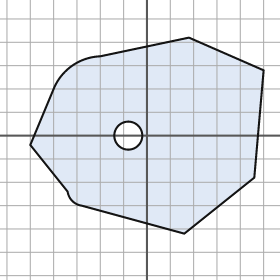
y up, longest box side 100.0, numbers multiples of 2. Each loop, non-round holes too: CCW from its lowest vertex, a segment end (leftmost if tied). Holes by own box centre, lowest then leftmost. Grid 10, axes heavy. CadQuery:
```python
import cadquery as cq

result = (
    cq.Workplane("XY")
    .moveTo(16.0, -42.0)
    .lineTo(46.0, -18.0)
    .lineTo(50.0, 28.0)
    .lineTo(18.0, 42.0)
    .lineTo(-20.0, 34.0)
    .threePointArc((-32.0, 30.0), (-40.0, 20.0))
    .lineTo(-50.0, -4.0)
    .lineTo(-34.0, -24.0)
    .threePointArc((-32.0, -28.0), (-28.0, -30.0))
    .close()
    .moveTo(-8.0, 0.0)
    .circle(6.0)
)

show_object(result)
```